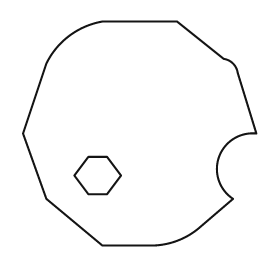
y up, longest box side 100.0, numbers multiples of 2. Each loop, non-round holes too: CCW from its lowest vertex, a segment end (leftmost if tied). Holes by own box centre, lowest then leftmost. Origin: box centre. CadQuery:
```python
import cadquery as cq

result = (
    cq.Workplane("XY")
    .moveTo(-16.0, -48.0)
    .lineTo(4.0, -48.0)
    .threePointArc((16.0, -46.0), (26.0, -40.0))
    .lineTo(40.0, -28.0)
    .threePointArc((34.0, -10.0), (50.0, 0.0))
    .lineTo(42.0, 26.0)
    .threePointArc((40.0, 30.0), (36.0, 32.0))
    .lineTo(16.0, 48.0)
    .lineTo(-16.0, 48.0)
    .threePointArc((-30.0, 42.0), (-40.0, 30.0))
    .lineTo(-50.0, 0.0)
    .lineTo(-40.0, -28.0)
    .close()
    .moveTo(-22.0, -26.0)
    .lineTo(-14.0, -26.0)
    .lineTo(-8.0, -18.0)
    .lineTo(-14.0, -10.0)
    .lineTo(-22.0, -10.0)
    .lineTo(-28.0, -18.0)
    .close()
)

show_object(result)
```